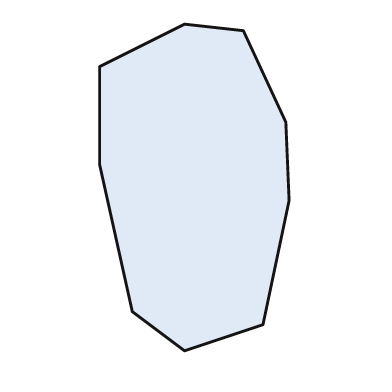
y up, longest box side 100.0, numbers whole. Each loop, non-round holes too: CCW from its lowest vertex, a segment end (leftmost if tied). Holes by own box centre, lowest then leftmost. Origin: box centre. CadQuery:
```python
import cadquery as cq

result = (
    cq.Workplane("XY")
    .moveTo(-3.0, -50.0)
    .lineTo(21.0, -42.0)
    .lineTo(29.0, -4.0)
    .lineTo(28.0, 20.0)
    .lineTo(15.0, 48.0)
    .lineTo(-3.0, 50.0)
    .lineTo(-29.0, 37.0)
    .lineTo(-29.0, 7.0)
    .lineTo(-19.0, -38.0)
    .close()
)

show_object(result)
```